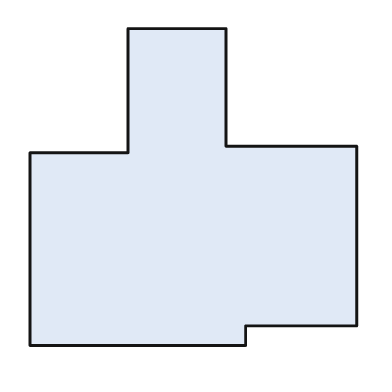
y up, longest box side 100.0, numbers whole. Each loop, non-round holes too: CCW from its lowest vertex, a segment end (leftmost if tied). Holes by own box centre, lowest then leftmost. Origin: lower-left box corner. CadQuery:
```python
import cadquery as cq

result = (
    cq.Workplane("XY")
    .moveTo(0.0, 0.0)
    .lineTo(66.0, 0.0)
    .lineTo(66.0, 6.0)
    .lineTo(100.0, 6.0)
    .lineTo(100.0, 61.0)
    .lineTo(60.0, 61.0)
    .lineTo(60.0, 97.0)
    .lineTo(30.0, 97.0)
    .lineTo(30.0, 59.0)
    .lineTo(0.0, 59.0)
    .close()
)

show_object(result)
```